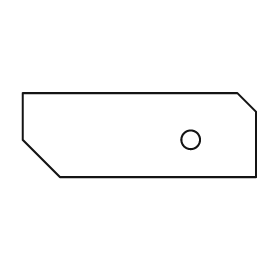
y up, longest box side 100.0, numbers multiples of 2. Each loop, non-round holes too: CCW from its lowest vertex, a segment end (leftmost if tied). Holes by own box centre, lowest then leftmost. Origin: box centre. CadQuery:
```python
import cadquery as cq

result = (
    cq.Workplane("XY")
    .moveTo(-34.0, -18.0)
    .lineTo(50.0, -18.0)
    .lineTo(50.0, 10.0)
    .lineTo(42.0, 18.0)
    .lineTo(-50.0, 18.0)
    .lineTo(-50.0, -2.0)
    .close()
    .moveTo(22.0, -2.0)
    .circle(4.0)
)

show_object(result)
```